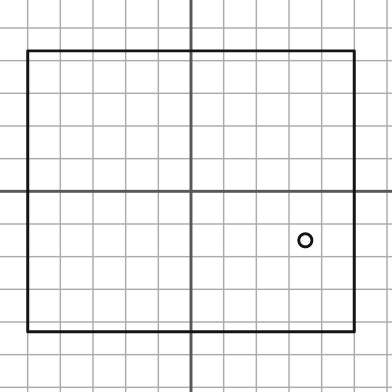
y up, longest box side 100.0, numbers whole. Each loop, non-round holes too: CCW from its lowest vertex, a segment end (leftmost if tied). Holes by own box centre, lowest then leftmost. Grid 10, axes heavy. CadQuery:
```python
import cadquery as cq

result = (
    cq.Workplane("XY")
    .moveTo(-50.0, -43.0)
    .lineTo(50.0, -43.0)
    .lineTo(50.0, 43.0)
    .lineTo(-50.0, 43.0)
    .close()
    .moveTo(35.0, -15.0)
    .circle(2.0)
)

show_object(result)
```